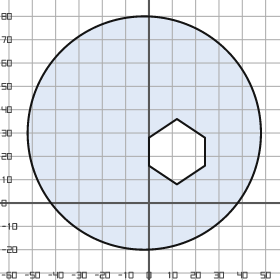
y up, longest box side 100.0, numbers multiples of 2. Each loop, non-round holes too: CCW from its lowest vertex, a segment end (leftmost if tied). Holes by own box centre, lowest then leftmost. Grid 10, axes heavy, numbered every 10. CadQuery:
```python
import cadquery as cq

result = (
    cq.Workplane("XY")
    .moveTo(-2.0, 30.0)
    .circle(50.0)
    .moveTo(12.0, 8.0)
    .lineTo(24.0, 16.0)
    .lineTo(24.0, 28.0)
    .lineTo(12.0, 36.0)
    .lineTo(0.0, 28.0)
    .lineTo(0.0, 16.0)
    .close()
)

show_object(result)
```